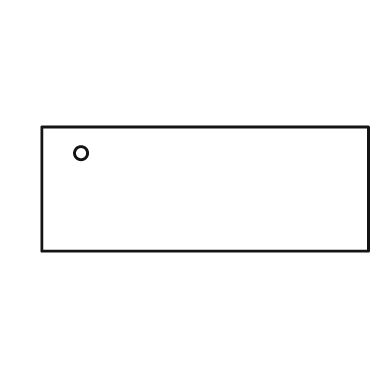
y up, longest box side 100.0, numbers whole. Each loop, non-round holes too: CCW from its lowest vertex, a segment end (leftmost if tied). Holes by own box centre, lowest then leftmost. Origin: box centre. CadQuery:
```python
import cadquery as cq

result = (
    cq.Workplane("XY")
    .moveTo(-50.0, -19.0)
    .lineTo(50.0, -19.0)
    .lineTo(50.0, 19.0)
    .lineTo(-50.0, 19.0)
    .close()
    .moveTo(-38.0, 11.0)
    .circle(2.0)
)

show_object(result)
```